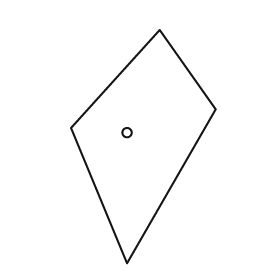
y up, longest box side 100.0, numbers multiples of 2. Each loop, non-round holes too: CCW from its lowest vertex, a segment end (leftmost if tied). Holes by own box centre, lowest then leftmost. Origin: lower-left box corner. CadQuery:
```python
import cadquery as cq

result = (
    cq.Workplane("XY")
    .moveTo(24.0, 0.0)
    .lineTo(62.0, 66.0)
    .lineTo(38.0, 100.0)
    .lineTo(0.0, 58.0)
    .close()
    .moveTo(24.0, 56.0)
    .circle(2.0)
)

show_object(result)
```